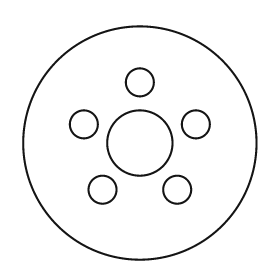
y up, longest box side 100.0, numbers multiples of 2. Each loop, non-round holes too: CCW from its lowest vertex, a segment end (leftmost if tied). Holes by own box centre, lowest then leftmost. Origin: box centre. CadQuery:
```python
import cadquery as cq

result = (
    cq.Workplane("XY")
    .moveTo(0.0, 0.0)
    .circle(50.0)
    .moveTo(-16.0, -20.0)
    .circle(6.0)
    .moveTo(16.0, -20.0)
    .circle(6.0)
    .moveTo(0.0, 0.0)
    .circle(14.0)
    .moveTo(-24.0, 8.0)
    .circle(6.0)
    .moveTo(24.0, 8.0)
    .circle(6.0)
    .moveTo(0.0, 26.0)
    .circle(6.0)
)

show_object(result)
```